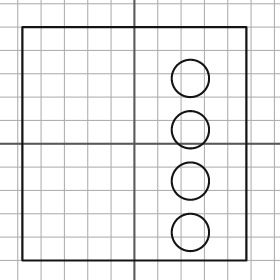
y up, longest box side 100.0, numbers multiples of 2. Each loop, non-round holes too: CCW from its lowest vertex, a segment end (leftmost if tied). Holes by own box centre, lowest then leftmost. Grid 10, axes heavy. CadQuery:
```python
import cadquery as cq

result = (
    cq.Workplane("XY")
    .moveTo(-48.0, -50.0)
    .lineTo(48.0, -50.0)
    .lineTo(48.0, 50.0)
    .lineTo(-48.0, 50.0)
    .close()
    .moveTo(24.0, -38.0)
    .circle(8.0)
    .moveTo(24.0, -16.0)
    .circle(8.0)
    .moveTo(24.0, 6.0)
    .circle(8.0)
    .moveTo(24.0, 28.0)
    .circle(8.0)
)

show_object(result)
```